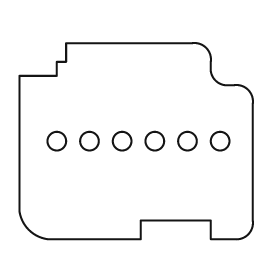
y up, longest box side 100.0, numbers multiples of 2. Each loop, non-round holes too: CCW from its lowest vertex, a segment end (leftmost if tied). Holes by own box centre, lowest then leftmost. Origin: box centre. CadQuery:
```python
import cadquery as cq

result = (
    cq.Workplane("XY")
    .moveTo(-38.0, -42.0)
    .lineTo(2.0, -42.0)
    .lineTo(2.0, -34.0)
    .lineTo(32.0, -34.0)
    .lineTo(32.0, -42.0)
    .lineTo(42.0, -42.0)
    .threePointArc((48.0, -40.0), (50.0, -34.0))
    .lineTo(50.0, 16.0)
    .threePointArc((48.0, 22.0), (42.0, 24.0))
    .lineTo(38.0, 24.0)
    .threePointArc((34.0, 26.0), (32.0, 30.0))
    .lineTo(32.0, 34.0)
    .threePointArc((30.0, 40.0), (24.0, 42.0))
    .lineTo(-30.0, 42.0)
    .lineTo(-30.0, 34.0)
    .lineTo(-34.0, 34.0)
    .lineTo(-34.0, 28.0)
    .lineTo(-50.0, 28.0)
    .lineTo(-50.0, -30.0)
    .threePointArc((-46.0, -38.0), (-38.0, -42.0))
    .close()
    .moveTo(-34.0, 0.0)
    .circle(4.0)
    .moveTo(-20.0, 0.0)
    .circle(4.0)
    .moveTo(-6.0, 0.0)
    .circle(4.0)
    .moveTo(8.0, 0.0)
    .circle(4.0)
    .moveTo(22.0, 0.0)
    .circle(4.0)
    .moveTo(36.0, 0.0)
    .circle(4.0)
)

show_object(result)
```